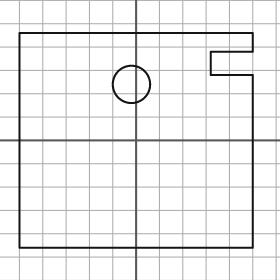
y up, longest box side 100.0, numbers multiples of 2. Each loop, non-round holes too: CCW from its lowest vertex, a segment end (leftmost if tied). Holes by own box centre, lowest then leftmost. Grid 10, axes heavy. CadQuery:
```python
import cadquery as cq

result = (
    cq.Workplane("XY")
    .moveTo(-50.0, -46.0)
    .lineTo(50.0, -46.0)
    .lineTo(50.0, 28.0)
    .lineTo(32.0, 28.0)
    .lineTo(32.0, 38.0)
    .lineTo(50.0, 38.0)
    .lineTo(50.0, 46.0)
    .lineTo(-50.0, 46.0)
    .close()
    .moveTo(-2.0, 24.0)
    .circle(8.0)
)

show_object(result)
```